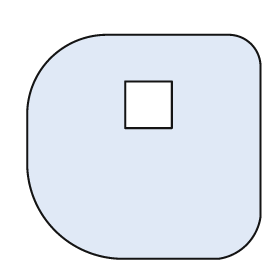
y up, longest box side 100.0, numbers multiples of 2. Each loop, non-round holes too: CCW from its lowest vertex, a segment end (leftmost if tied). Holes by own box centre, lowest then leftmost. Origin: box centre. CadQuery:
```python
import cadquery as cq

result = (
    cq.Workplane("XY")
    .moveTo(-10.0, -48.0)
    .lineTo(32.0, -48.0)
    .threePointArc((44.0, -42.0), (50.0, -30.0))
    .lineTo(50.0, 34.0)
    .threePointArc((46.0, 44.0), (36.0, 48.0))
    .lineTo(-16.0, 48.0)
    .threePointArc((-40.0, 38.0), (-50.0, 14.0))
    .lineTo(-50.0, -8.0)
    .threePointArc((-38.0, -36.0), (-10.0, -48.0))
    .close()
    .moveTo(-8.0, 8.0)
    .lineTo(12.0, 8.0)
    .lineTo(12.0, 28.0)
    .lineTo(-8.0, 28.0)
    .close()
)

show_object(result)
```